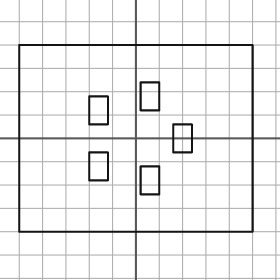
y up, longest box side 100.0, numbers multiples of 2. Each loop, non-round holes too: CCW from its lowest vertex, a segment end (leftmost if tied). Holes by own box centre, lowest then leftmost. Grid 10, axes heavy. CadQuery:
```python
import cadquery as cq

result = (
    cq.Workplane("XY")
    .moveTo(-50.0, -40.0)
    .lineTo(50.0, -40.0)
    .lineTo(50.0, 40.0)
    .lineTo(-50.0, 40.0)
    .close()
    .moveTo(2.0, -24.0)
    .lineTo(10.0, -24.0)
    .lineTo(10.0, -12.0)
    .lineTo(2.0, -12.0)
    .close()
    .moveTo(-20.0, -18.0)
    .lineTo(-12.0, -18.0)
    .lineTo(-12.0, -6.0)
    .lineTo(-20.0, -6.0)
    .close()
    .moveTo(16.0, -6.0)
    .lineTo(24.0, -6.0)
    .lineTo(24.0, 6.0)
    .lineTo(16.0, 6.0)
    .close()
    .moveTo(-20.0, 6.0)
    .lineTo(-12.0, 6.0)
    .lineTo(-12.0, 18.0)
    .lineTo(-20.0, 18.0)
    .close()
    .moveTo(2.0, 12.0)
    .lineTo(10.0, 12.0)
    .lineTo(10.0, 24.0)
    .lineTo(2.0, 24.0)
    .close()
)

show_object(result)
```